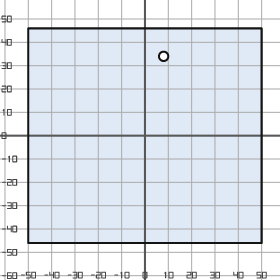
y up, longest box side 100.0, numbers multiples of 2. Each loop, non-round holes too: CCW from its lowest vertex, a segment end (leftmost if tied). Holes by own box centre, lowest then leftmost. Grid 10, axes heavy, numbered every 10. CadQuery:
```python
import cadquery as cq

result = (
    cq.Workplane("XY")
    .moveTo(-50.0, -46.0)
    .lineTo(50.0, -46.0)
    .lineTo(50.0, 46.0)
    .lineTo(-50.0, 46.0)
    .close()
    .moveTo(8.0, 34.0)
    .circle(2.0)
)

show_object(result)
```